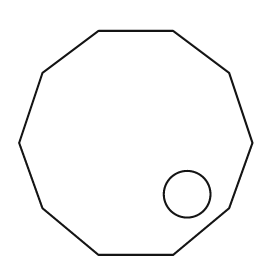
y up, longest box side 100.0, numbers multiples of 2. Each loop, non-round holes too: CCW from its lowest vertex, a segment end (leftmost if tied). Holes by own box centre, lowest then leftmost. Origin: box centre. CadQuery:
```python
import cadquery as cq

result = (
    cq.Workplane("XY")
    .moveTo(-16.0, -48.0)
    .lineTo(16.0, -48.0)
    .lineTo(40.0, -28.0)
    .lineTo(50.0, 0.0)
    .lineTo(40.0, 30.0)
    .lineTo(16.0, 48.0)
    .lineTo(-16.0, 48.0)
    .lineTo(-40.0, 30.0)
    .lineTo(-50.0, 0.0)
    .lineTo(-40.0, -28.0)
    .close()
    .moveTo(22.0, -22.0)
    .circle(10.0)
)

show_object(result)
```